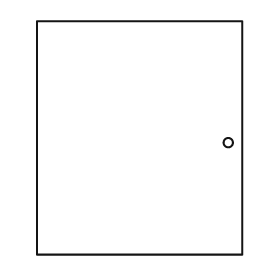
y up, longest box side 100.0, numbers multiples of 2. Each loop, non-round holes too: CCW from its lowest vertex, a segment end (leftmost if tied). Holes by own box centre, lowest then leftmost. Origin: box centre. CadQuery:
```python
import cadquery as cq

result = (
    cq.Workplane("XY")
    .moveTo(-44.0, -50.0)
    .lineTo(44.0, -50.0)
    .lineTo(44.0, 50.0)
    .lineTo(-44.0, 50.0)
    .close()
    .moveTo(38.0, -2.0)
    .circle(2.0)
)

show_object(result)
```